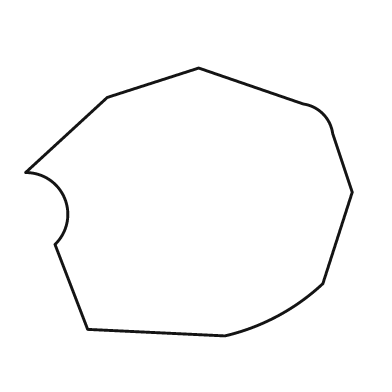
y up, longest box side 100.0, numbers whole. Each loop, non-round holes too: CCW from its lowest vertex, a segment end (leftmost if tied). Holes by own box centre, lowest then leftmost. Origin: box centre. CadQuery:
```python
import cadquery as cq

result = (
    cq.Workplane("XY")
    .moveTo(11.0, -41.0)
    .threePointArc((27.0, -35.0), (41.0, -25.0))
    .lineTo(50.0, 3.0)
    .lineTo(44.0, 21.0)
    .threePointArc((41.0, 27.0), (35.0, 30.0))
    .lineTo(3.0, 41.0)
    .lineTo(-25.0, 32.0)
    .lineTo(-50.0, 9.0)
    .threePointArc((-38.0, 1.0), (-41.0, -13.0))
    .lineTo(-31.0, -39.0)
    .close()
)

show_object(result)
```